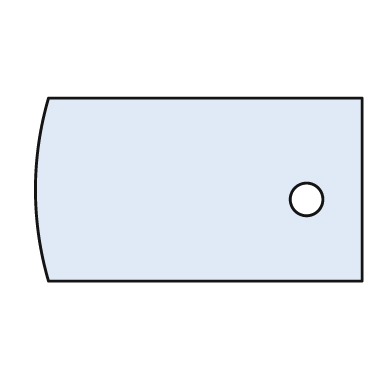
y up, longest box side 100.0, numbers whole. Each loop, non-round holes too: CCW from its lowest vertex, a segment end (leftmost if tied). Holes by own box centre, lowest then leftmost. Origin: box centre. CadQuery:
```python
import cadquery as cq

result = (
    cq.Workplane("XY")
    .moveTo(-46.0, -28.0)
    .lineTo(50.0, -28.0)
    .lineTo(50.0, 28.0)
    .lineTo(-46.0, 28.0)
    .threePointArc((-50.0, 0.0), (-46.0, -28.0))
    .close()
    .moveTo(33.0, -3.0)
    .circle(5.0)
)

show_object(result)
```